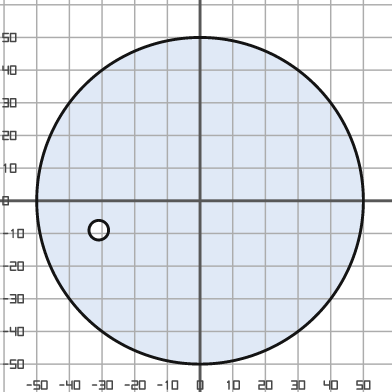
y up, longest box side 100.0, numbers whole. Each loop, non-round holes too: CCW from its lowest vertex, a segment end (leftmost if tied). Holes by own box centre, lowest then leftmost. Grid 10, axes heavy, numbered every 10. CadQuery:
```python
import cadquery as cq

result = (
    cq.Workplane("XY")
    .moveTo(0.0, 0.0)
    .circle(50.0)
    .moveTo(-31.0, -9.0)
    .circle(3.0)
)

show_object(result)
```